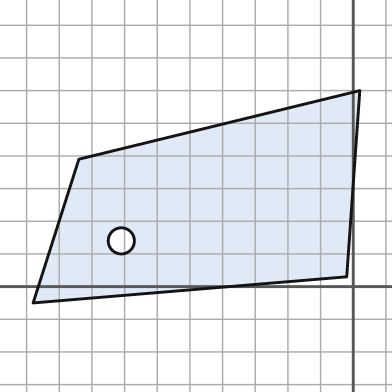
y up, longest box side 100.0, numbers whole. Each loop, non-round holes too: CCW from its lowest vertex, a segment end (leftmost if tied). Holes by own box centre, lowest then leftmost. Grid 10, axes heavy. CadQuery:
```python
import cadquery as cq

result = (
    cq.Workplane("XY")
    .moveTo(-98.0, -5.0)
    .lineTo(-2.0, 3.0)
    .lineTo(2.0, 60.0)
    .lineTo(-84.0, 39.0)
    .close()
    .moveTo(-71.0, 14.0)
    .circle(4.0)
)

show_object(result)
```